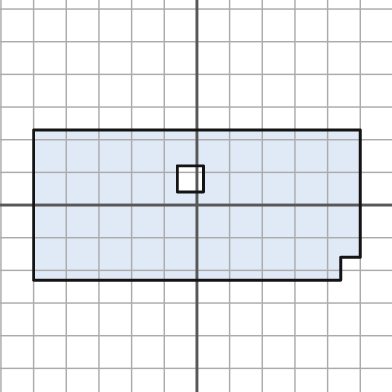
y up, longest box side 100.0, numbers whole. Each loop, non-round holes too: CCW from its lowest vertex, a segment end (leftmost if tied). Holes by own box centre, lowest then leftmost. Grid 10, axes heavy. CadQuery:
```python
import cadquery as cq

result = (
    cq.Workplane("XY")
    .moveTo(-50.0, -23.0)
    .lineTo(44.0, -23.0)
    .lineTo(44.0, -16.0)
    .lineTo(50.0, -16.0)
    .lineTo(50.0, 23.0)
    .lineTo(-50.0, 23.0)
    .close()
    .moveTo(-6.0, 4.0)
    .lineTo(2.0, 4.0)
    .lineTo(2.0, 12.0)
    .lineTo(-6.0, 12.0)
    .close()
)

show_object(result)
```